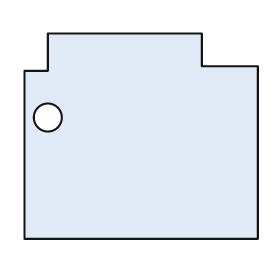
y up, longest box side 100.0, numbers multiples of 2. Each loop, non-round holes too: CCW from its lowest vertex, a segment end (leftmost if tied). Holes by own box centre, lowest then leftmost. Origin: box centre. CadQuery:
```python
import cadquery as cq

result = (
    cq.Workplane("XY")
    .moveTo(-50.0, -44.0)
    .lineTo(50.0, -44.0)
    .lineTo(50.0, 30.0)
    .lineTo(26.0, 30.0)
    .lineTo(26.0, 44.0)
    .lineTo(-40.0, 44.0)
    .lineTo(-40.0, 28.0)
    .lineTo(-50.0, 28.0)
    .close()
    .moveTo(-40.0, 8.0)
    .circle(6.0)
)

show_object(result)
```